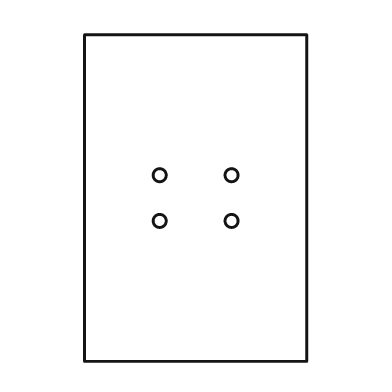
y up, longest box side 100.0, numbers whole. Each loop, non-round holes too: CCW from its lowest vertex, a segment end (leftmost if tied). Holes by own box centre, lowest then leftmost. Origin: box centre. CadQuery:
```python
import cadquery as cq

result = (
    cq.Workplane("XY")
    .moveTo(-34.0, -50.0)
    .lineTo(34.0, -50.0)
    .lineTo(34.0, 50.0)
    .lineTo(-34.0, 50.0)
    .close()
    .moveTo(-11.0, -7.0)
    .circle(2.0)
    .moveTo(11.0, -7.0)
    .circle(2.0)
    .moveTo(-11.0, 7.0)
    .circle(2.0)
    .moveTo(11.0, 7.0)
    .circle(2.0)
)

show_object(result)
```